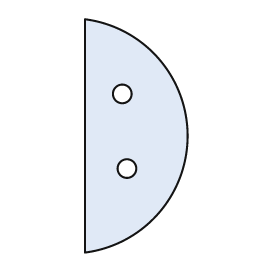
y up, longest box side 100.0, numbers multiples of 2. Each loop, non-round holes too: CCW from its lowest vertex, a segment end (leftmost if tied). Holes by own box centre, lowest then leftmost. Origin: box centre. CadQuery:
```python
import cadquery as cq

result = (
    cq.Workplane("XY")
    .moveTo(-22.0, -50.0)
    .threePointArc((22.0, 0.0), (-22.0, 50.0))
    .close()
    .moveTo(-4.0, -14.0)
    .circle(4.0)
    .moveTo(-6.0, 18.0)
    .circle(4.0)
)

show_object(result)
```